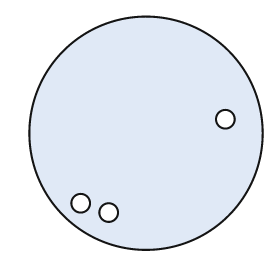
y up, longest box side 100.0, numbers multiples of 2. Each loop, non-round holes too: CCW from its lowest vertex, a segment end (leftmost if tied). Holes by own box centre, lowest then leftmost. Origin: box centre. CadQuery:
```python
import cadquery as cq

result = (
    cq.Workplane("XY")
    .moveTo(0.0, 0.0)
    .circle(50.0)
    .moveTo(-16.0, -34.0)
    .circle(4.0)
    .moveTo(-28.0, -30.0)
    .circle(4.0)
    .moveTo(34.0, 6.0)
    .circle(4.0)
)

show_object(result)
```